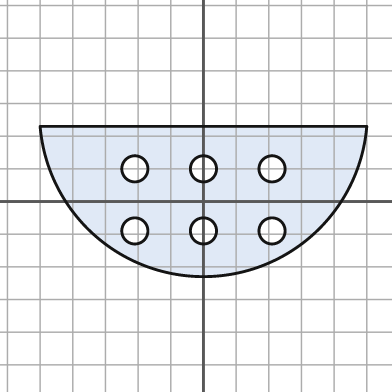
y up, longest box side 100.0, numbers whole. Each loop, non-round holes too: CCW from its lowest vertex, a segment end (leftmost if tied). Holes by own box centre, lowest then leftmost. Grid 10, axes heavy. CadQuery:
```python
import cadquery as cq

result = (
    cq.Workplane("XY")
    .moveTo(-50.0, 23.0)
    .threePointArc((0.0, -23.0), (50.0, 23.0))
    .close()
    .moveTo(-21.0, -9.0)
    .circle(4.0)
    .moveTo(0.0, -9.0)
    .circle(4.0)
    .moveTo(21.0, -9.0)
    .circle(4.0)
    .moveTo(-21.0, 10.0)
    .circle(4.0)
    .moveTo(0.0, 10.0)
    .circle(4.0)
    .moveTo(21.0, 10.0)
    .circle(4.0)
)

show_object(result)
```